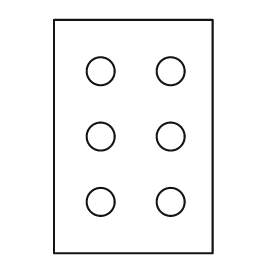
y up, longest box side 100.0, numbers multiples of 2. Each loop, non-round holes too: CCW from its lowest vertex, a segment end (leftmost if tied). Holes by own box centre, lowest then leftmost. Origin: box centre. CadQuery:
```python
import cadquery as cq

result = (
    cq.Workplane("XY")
    .moveTo(-34.0, -50.0)
    .lineTo(34.0, -50.0)
    .lineTo(34.0, 50.0)
    .lineTo(-34.0, 50.0)
    .close()
    .moveTo(-14.0, -28.0)
    .circle(6.0)
    .moveTo(16.0, -28.0)
    .circle(6.0)
    .moveTo(-14.0, 0.0)
    .circle(6.0)
    .moveTo(16.0, 0.0)
    .circle(6.0)
    .moveTo(-14.0, 28.0)
    .circle(6.0)
    .moveTo(16.0, 28.0)
    .circle(6.0)
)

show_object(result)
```